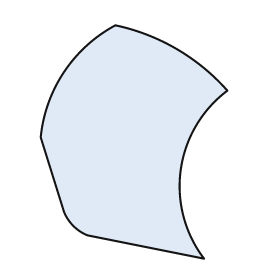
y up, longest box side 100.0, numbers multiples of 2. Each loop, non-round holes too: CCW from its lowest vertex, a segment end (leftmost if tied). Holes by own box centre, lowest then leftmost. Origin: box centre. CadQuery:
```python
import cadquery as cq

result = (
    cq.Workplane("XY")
    .moveTo(30.0, -50.0)
    .threePointArc((20.0, -12.0), (40.0, 22.0))
    .threePointArc((18.0, 40.0), (-8.0, 50.0))
    .threePointArc((-30.0, 30.0), (-40.0, 2.0))
    .lineTo(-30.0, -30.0)
    .threePointArc((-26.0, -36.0), (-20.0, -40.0))
    .close()
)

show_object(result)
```